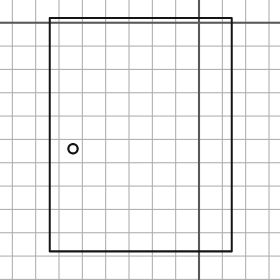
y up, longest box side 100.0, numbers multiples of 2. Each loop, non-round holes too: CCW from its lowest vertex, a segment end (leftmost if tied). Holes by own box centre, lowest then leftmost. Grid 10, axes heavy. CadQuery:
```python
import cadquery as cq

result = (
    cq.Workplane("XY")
    .moveTo(-64.0, -98.0)
    .lineTo(14.0, -98.0)
    .lineTo(14.0, 2.0)
    .lineTo(-64.0, 2.0)
    .close()
    .moveTo(-54.0, -54.0)
    .circle(2.0)
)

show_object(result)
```